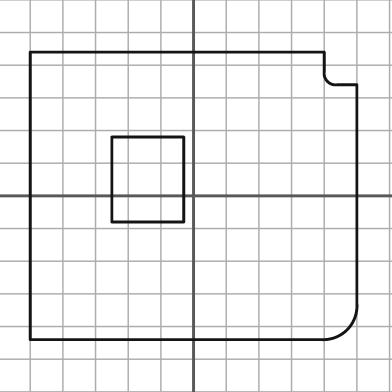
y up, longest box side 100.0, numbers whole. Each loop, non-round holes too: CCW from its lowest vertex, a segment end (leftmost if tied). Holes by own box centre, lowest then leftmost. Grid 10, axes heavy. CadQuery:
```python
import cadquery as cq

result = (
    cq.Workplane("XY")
    .moveTo(-50.0, -44.0)
    .lineTo(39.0, -44.0)
    .threePointArc((47.0, -41.0), (50.0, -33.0))
    .lineTo(50.0, 34.0)
    .lineTo(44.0, 34.0)
    .threePointArc((41.0, 35.0), (40.0, 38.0))
    .lineTo(40.0, 44.0)
    .lineTo(-50.0, 44.0)
    .close()
    .moveTo(-25.0, -8.0)
    .lineTo(-3.0, -8.0)
    .lineTo(-3.0, 18.0)
    .lineTo(-25.0, 18.0)
    .close()
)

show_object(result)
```